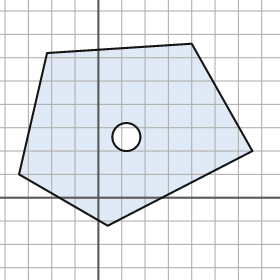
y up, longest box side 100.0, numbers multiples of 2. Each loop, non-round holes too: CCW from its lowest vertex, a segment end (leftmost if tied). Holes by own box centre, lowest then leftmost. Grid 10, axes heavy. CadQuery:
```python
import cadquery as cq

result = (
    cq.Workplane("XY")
    .moveTo(4.0, -12.0)
    .lineTo(66.0, 20.0)
    .lineTo(40.0, 66.0)
    .lineTo(-22.0, 62.0)
    .lineTo(-34.0, 10.0)
    .close()
    .moveTo(12.0, 26.0)
    .circle(6.0)
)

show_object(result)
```